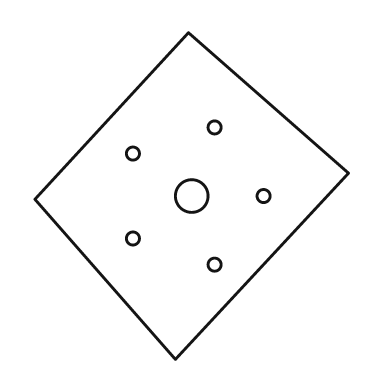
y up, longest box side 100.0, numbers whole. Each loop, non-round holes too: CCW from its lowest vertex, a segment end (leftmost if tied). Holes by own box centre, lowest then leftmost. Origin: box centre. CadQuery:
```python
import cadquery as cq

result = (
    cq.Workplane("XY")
    .moveTo(-5.0, -50.0)
    .lineTo(48.0, 7.0)
    .lineTo(-1.0, 50.0)
    .lineTo(-48.0, -1.0)
    .close()
    .moveTo(7.0, -21.0)
    .circle(2.0)
    .moveTo(-18.0, -13.0)
    .circle(2.0)
    .moveTo(0.0, 0.0)
    .circle(5.0)
    .moveTo(22.0, 0.0)
    .circle(2.0)
    .moveTo(-18.0, 13.0)
    .circle(2.0)
    .moveTo(7.0, 21.0)
    .circle(2.0)
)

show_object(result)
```